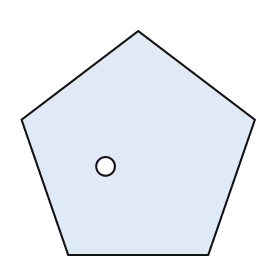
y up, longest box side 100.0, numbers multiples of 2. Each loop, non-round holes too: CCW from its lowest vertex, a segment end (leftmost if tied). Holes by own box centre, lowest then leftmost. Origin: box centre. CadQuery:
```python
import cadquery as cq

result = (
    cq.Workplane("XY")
    .moveTo(-30.0, -48.0)
    .lineTo(30.0, -48.0)
    .lineTo(50.0, 10.0)
    .lineTo(0.0, 48.0)
    .lineTo(-50.0, 10.0)
    .close()
    .moveTo(-14.0, -10.0)
    .circle(4.0)
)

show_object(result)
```